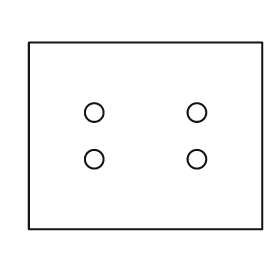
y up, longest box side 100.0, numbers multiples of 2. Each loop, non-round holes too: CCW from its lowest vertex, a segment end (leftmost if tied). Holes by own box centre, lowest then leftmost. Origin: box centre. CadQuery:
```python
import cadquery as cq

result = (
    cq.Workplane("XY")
    .moveTo(-50.0, -40.0)
    .lineTo(50.0, -40.0)
    .lineTo(50.0, 40.0)
    .lineTo(-50.0, 40.0)
    .close()
    .moveTo(-22.0, -10.0)
    .circle(4.0)
    .moveTo(22.0, -10.0)
    .circle(4.0)
    .moveTo(-22.0, 10.0)
    .circle(4.0)
    .moveTo(22.0, 10.0)
    .circle(4.0)
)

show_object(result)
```